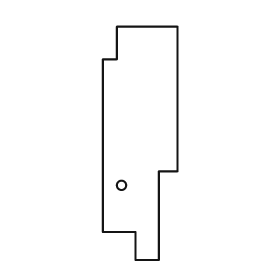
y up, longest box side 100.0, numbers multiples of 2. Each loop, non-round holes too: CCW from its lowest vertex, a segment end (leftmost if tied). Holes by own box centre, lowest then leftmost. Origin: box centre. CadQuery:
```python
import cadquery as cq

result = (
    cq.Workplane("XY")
    .moveTo(-2.0, -50.0)
    .lineTo(8.0, -50.0)
    .lineTo(8.0, -12.0)
    .lineTo(16.0, -12.0)
    .lineTo(16.0, 50.0)
    .lineTo(-10.0, 50.0)
    .lineTo(-10.0, 36.0)
    .lineTo(-16.0, 36.0)
    .lineTo(-16.0, -38.0)
    .lineTo(-2.0, -38.0)
    .close()
    .moveTo(-8.0, -18.0)
    .circle(2.0)
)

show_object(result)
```